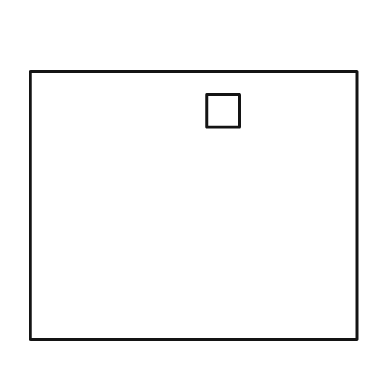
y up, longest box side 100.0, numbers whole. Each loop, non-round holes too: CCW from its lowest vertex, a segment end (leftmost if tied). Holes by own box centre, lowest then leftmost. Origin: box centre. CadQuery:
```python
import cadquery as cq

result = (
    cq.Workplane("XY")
    .moveTo(-50.0, -41.0)
    .lineTo(50.0, -41.0)
    .lineTo(50.0, 41.0)
    .lineTo(-50.0, 41.0)
    .close()
    .moveTo(4.0, 24.0)
    .lineTo(14.0, 24.0)
    .lineTo(14.0, 34.0)
    .lineTo(4.0, 34.0)
    .close()
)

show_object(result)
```